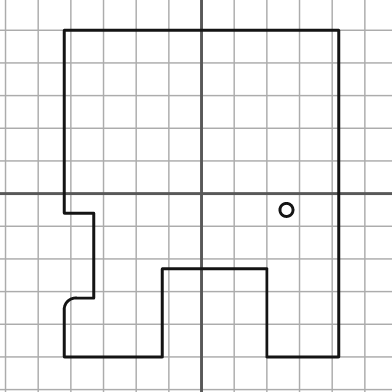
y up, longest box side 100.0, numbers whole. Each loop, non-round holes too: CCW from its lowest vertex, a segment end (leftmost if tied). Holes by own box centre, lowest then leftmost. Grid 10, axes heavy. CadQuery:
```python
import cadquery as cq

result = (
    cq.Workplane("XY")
    .moveTo(-42.0, -50.0)
    .lineTo(-12.0, -50.0)
    .lineTo(-12.0, -23.0)
    .lineTo(20.0, -23.0)
    .lineTo(20.0, -50.0)
    .lineTo(42.0, -50.0)
    .lineTo(42.0, 50.0)
    .lineTo(-42.0, 50.0)
    .lineTo(-42.0, -6.0)
    .lineTo(-33.0, -6.0)
    .lineTo(-33.0, -32.0)
    .lineTo(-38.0, -32.0)
    .threePointArc((-41.0, -33.0), (-42.0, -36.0))
    .close()
    .moveTo(26.0, -5.0)
    .circle(2.0)
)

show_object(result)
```